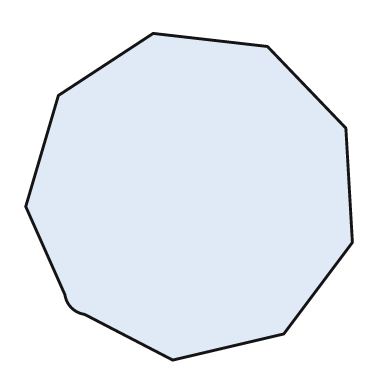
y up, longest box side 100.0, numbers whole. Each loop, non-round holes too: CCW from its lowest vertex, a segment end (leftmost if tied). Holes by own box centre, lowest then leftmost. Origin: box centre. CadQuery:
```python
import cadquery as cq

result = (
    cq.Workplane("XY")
    .moveTo(-5.0, -50.0)
    .lineTo(29.0, -42.0)
    .lineTo(50.0, -14.0)
    .lineTo(48.0, 21.0)
    .lineTo(24.0, 46.0)
    .lineTo(-11.0, 50.0)
    .lineTo(-40.0, 31.0)
    .lineTo(-50.0, -3.0)
    .lineTo(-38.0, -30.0)
    .threePointArc((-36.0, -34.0), (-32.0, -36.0))
    .close()
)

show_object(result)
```